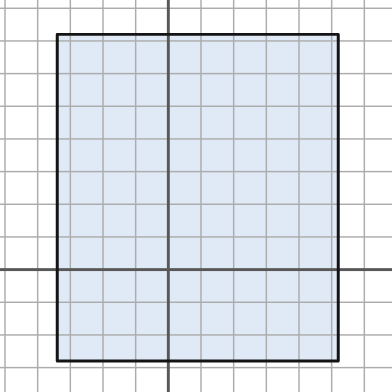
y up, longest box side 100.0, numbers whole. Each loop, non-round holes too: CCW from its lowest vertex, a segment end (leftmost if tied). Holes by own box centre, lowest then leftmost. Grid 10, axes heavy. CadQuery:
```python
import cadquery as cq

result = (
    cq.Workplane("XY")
    .moveTo(-34.0, -28.0)
    .lineTo(52.0, -28.0)
    .lineTo(52.0, 72.0)
    .lineTo(-34.0, 72.0)
    .close()
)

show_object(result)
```